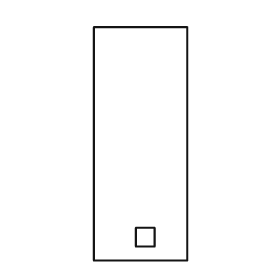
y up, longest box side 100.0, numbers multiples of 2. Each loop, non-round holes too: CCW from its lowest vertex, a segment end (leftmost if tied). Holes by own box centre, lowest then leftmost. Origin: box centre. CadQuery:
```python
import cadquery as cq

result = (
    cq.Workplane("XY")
    .moveTo(-20.0, -50.0)
    .lineTo(20.0, -50.0)
    .lineTo(20.0, 50.0)
    .lineTo(-20.0, 50.0)
    .close()
    .moveTo(-2.0, -44.0)
    .lineTo(6.0, -44.0)
    .lineTo(6.0, -36.0)
    .lineTo(-2.0, -36.0)
    .close()
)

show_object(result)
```